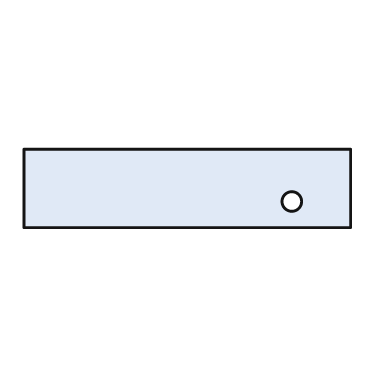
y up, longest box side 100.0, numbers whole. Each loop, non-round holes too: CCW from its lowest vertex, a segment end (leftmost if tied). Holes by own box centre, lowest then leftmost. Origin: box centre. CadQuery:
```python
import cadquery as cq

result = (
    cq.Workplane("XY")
    .moveTo(-50.0, -12.0)
    .lineTo(50.0, -12.0)
    .lineTo(50.0, 12.0)
    .lineTo(-50.0, 12.0)
    .close()
    .moveTo(32.0, -4.0)
    .circle(3.0)
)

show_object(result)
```